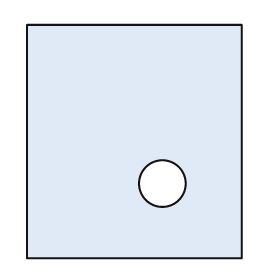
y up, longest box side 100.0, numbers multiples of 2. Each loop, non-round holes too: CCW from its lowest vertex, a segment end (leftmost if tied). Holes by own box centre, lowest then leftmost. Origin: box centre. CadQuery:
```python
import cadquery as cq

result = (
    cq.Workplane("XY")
    .moveTo(-46.0, -50.0)
    .lineTo(46.0, -50.0)
    .lineTo(46.0, 50.0)
    .lineTo(-46.0, 50.0)
    .close()
    .moveTo(12.0, -18.0)
    .circle(10.0)
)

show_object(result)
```